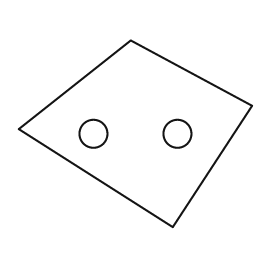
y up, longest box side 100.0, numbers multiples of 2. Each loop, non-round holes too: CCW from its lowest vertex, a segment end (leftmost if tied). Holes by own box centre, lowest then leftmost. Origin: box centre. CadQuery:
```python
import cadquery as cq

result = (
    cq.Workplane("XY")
    .moveTo(16.0, -40.0)
    .lineTo(50.0, 12.0)
    .lineTo(-2.0, 40.0)
    .lineTo(-50.0, 2.0)
    .close()
    .moveTo(-18.0, 0.0)
    .circle(6.0)
    .moveTo(18.0, 0.0)
    .circle(6.0)
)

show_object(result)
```